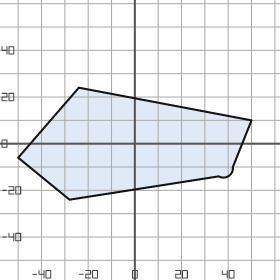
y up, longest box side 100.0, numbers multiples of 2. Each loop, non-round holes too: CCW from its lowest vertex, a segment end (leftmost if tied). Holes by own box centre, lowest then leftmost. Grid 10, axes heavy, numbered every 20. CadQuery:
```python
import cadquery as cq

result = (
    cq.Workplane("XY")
    .moveTo(-28.0, -24.0)
    .lineTo(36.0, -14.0)
    .threePointArc((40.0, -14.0), (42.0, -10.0))
    .lineTo(50.0, 10.0)
    .lineTo(-24.0, 24.0)
    .lineTo(-50.0, -6.0)
    .close()
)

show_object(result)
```